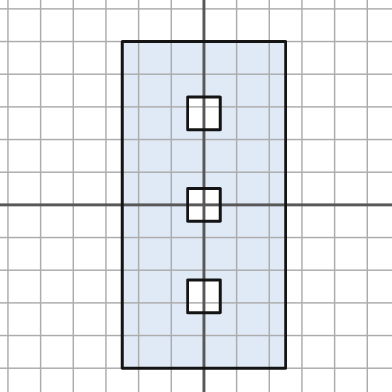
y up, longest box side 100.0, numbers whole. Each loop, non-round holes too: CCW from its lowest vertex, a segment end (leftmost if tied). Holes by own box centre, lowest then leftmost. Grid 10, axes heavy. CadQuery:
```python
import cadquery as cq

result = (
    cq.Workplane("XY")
    .moveTo(-25.0, -50.0)
    .lineTo(25.0, -50.0)
    .lineTo(25.0, 50.0)
    .lineTo(-25.0, 50.0)
    .close()
    .moveTo(-5.0, -33.0)
    .lineTo(5.0, -33.0)
    .lineTo(5.0, -23.0)
    .lineTo(-5.0, -23.0)
    .close()
    .moveTo(-5.0, -5.0)
    .lineTo(5.0, -5.0)
    .lineTo(5.0, 5.0)
    .lineTo(-5.0, 5.0)
    .close()
    .moveTo(-5.0, 23.0)
    .lineTo(5.0, 23.0)
    .lineTo(5.0, 33.0)
    .lineTo(-5.0, 33.0)
    .close()
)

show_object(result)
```